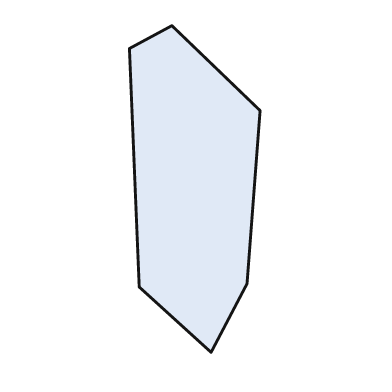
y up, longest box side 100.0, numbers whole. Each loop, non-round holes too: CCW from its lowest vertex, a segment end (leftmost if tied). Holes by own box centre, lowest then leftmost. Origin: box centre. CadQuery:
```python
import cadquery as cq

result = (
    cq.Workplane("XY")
    .moveTo(5.0, -50.0)
    .lineTo(16.0, -29.0)
    .lineTo(20.0, 24.0)
    .lineTo(-7.0, 50.0)
    .lineTo(-20.0, 43.0)
    .lineTo(-17.0, -30.0)
    .close()
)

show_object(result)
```